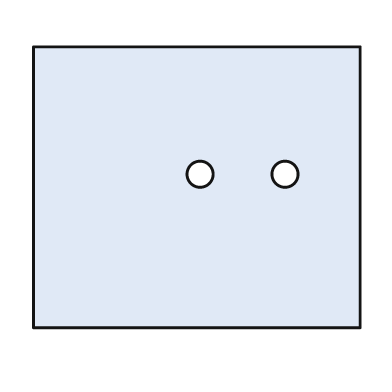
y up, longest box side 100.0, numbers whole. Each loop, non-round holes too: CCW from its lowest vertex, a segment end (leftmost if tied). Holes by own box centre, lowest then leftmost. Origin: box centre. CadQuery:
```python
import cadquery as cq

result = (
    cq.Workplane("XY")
    .moveTo(-50.0, -43.0)
    .lineTo(50.0, -43.0)
    .lineTo(50.0, 43.0)
    .lineTo(-50.0, 43.0)
    .close()
    .moveTo(1.0, 4.0)
    .circle(4.0)
    .moveTo(27.0, 4.0)
    .circle(4.0)
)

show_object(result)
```